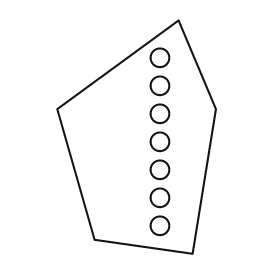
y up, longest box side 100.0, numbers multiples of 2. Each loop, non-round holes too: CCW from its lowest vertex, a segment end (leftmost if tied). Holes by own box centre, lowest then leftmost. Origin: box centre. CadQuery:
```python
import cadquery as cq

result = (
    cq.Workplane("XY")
    .moveTo(24.0, -50.0)
    .lineTo(34.0, 12.0)
    .lineTo(18.0, 50.0)
    .lineTo(-34.0, 12.0)
    .lineTo(-18.0, -44.0)
    .close()
    .moveTo(10.0, -38.0)
    .circle(4.0)
    .moveTo(10.0, -26.0)
    .circle(4.0)
    .moveTo(10.0, -14.0)
    .circle(4.0)
    .moveTo(10.0, -2.0)
    .circle(4.0)
    .moveTo(10.0, 10.0)
    .circle(4.0)
    .moveTo(10.0, 22.0)
    .circle(4.0)
    .moveTo(10.0, 34.0)
    .circle(4.0)
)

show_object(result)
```